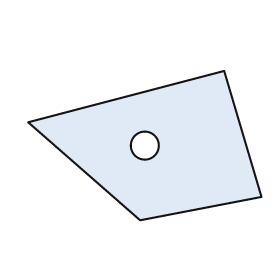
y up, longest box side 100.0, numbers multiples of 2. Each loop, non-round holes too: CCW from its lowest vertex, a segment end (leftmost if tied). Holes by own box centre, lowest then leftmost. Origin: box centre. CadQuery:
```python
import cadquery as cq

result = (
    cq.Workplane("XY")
    .moveTo(-2.0, -32.0)
    .lineTo(50.0, -22.0)
    .lineTo(34.0, 32.0)
    .lineTo(-50.0, 10.0)
    .close()
    .moveTo(0.0, 0.0)
    .circle(6.0)
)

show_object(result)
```